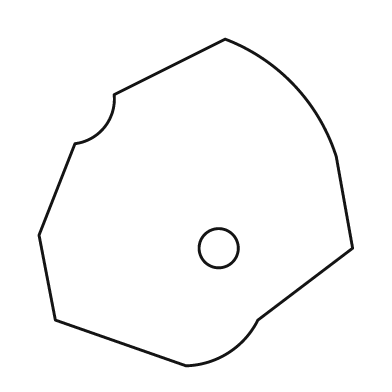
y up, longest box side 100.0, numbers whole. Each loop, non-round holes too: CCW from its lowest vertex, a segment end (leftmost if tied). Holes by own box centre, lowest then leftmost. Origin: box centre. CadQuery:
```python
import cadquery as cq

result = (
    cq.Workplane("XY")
    .moveTo(-3.0, -50.0)
    .threePointArc((10.0, -46.0), (19.0, -36.0))
    .lineTo(48.0, -14.0)
    .lineTo(43.0, 14.0)
    .threePointArc((30.0, 36.0), (9.0, 50.0))
    .lineTo(-25.0, 33.0)
    .threePointArc((-28.0, 23.0), (-37.0, 18.0))
    .lineTo(-48.0, -10.0)
    .lineTo(-43.0, -36.0)
    .close()
    .moveTo(7.0, -14.0)
    .circle(6.0)
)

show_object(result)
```